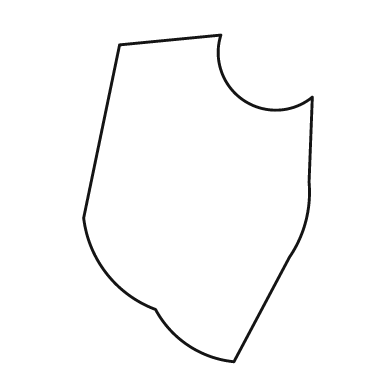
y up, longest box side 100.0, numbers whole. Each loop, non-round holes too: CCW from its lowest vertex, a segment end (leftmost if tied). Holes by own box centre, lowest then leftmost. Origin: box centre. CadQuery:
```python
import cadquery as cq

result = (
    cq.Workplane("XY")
    .moveTo(11.0, -50.0)
    .lineTo(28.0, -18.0)
    .threePointArc((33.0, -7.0), (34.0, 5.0))
    .lineTo(35.0, 31.0)
    .threePointArc((14.0, 30.0), (7.0, 50.0))
    .lineTo(-24.0, 47.0)
    .lineTo(-35.0, -6.0)
    .threePointArc((-28.0, -23.0), (-13.0, -34.0))
    .threePointArc((-3.0, -45.0), (11.0, -50.0))
    .close()
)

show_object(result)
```